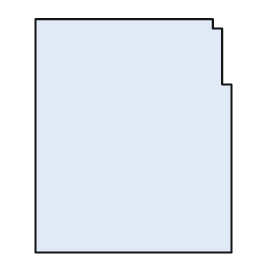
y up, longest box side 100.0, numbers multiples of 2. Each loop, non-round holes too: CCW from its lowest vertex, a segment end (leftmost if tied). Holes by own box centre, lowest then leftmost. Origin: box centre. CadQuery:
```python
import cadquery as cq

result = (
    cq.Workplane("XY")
    .moveTo(-42.0, -50.0)
    .lineTo(42.0, -50.0)
    .lineTo(42.0, 22.0)
    .lineTo(38.0, 22.0)
    .lineTo(38.0, 46.0)
    .lineTo(34.0, 46.0)
    .lineTo(34.0, 50.0)
    .lineTo(-42.0, 50.0)
    .close()
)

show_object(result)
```